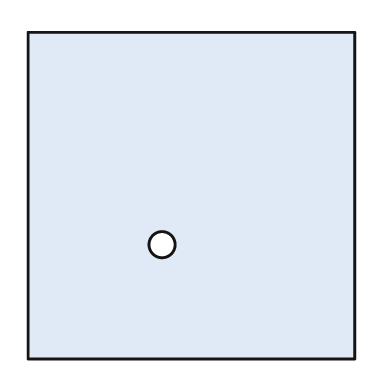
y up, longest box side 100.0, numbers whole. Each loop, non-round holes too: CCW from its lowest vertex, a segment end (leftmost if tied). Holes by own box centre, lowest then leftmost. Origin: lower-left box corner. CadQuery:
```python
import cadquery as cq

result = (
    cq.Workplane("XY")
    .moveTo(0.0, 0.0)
    .lineTo(100.0, 0.0)
    .lineTo(100.0, 100.0)
    .lineTo(0.0, 100.0)
    .close()
    .moveTo(41.0, 35.0)
    .circle(4.0)
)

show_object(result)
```